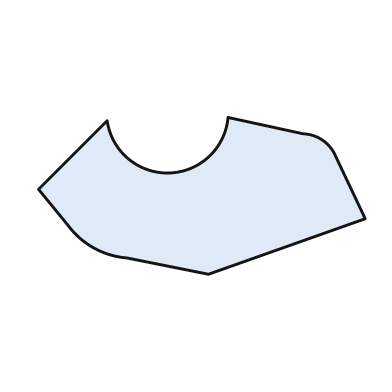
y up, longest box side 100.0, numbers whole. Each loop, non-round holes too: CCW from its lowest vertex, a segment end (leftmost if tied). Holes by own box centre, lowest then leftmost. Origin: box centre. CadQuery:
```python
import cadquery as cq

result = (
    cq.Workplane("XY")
    .moveTo(2.0, -24.0)
    .lineTo(50.0, -7.0)
    .lineTo(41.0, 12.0)
    .threePointArc((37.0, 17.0), (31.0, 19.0))
    .lineTo(8.0, 24.0)
    .threePointArc((-10.0, 7.0), (-29.0, 23.0))
    .lineTo(-50.0, 2.0)
    .lineTo(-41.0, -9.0)
    .threePointArc((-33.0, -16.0), (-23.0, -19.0))
    .close()
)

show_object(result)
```